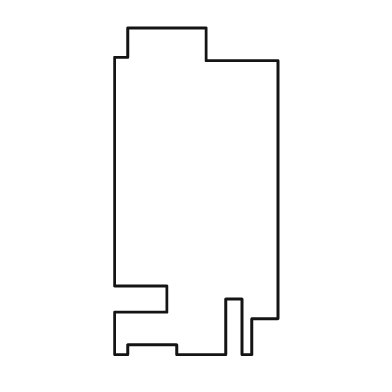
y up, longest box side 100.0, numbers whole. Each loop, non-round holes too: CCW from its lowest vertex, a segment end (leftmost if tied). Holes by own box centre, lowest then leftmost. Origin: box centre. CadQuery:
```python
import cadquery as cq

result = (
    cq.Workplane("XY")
    .moveTo(-25.0, -50.0)
    .lineTo(-21.0, -50.0)
    .lineTo(-21.0, -47.0)
    .lineTo(-6.0, -47.0)
    .lineTo(-6.0, -50.0)
    .lineTo(9.0, -50.0)
    .lineTo(9.0, -33.0)
    .lineTo(14.0, -33.0)
    .lineTo(14.0, -50.0)
    .lineTo(17.0, -50.0)
    .lineTo(17.0, -39.0)
    .lineTo(25.0, -39.0)
    .lineTo(25.0, 40.0)
    .lineTo(3.0, 40.0)
    .lineTo(3.0, 50.0)
    .lineTo(-21.0, 50.0)
    .lineTo(-21.0, 41.0)
    .lineTo(-25.0, 41.0)
    .lineTo(-25.0, -29.0)
    .lineTo(-9.0, -29.0)
    .lineTo(-9.0, -37.0)
    .lineTo(-25.0, -37.0)
    .close()
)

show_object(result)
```